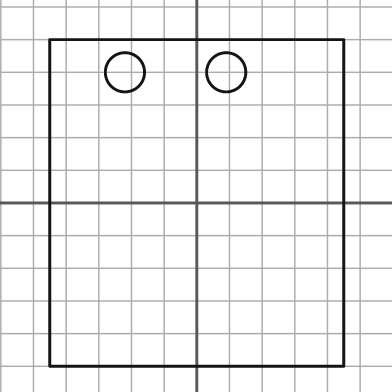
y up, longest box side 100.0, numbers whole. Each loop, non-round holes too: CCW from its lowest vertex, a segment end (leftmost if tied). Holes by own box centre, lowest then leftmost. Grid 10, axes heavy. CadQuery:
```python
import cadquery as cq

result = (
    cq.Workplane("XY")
    .moveTo(-45.0, -50.0)
    .lineTo(45.0, -50.0)
    .lineTo(45.0, 50.0)
    .lineTo(-45.0, 50.0)
    .close()
    .moveTo(-22.0, 40.0)
    .circle(6.0)
    .moveTo(9.0, 40.0)
    .circle(6.0)
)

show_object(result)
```